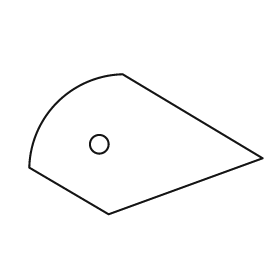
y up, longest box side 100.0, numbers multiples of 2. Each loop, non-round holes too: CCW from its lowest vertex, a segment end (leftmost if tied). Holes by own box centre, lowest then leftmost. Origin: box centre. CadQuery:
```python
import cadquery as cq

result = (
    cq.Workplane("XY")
    .moveTo(-16.0, -30.0)
    .lineTo(50.0, -6.0)
    .lineTo(-10.0, 30.0)
    .threePointArc((-38.0, 18.0), (-50.0, -10.0))
    .close()
    .moveTo(-20.0, 0.0)
    .circle(4.0)
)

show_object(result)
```